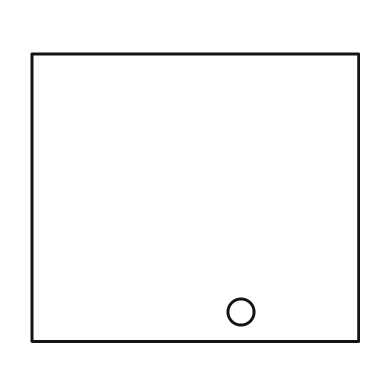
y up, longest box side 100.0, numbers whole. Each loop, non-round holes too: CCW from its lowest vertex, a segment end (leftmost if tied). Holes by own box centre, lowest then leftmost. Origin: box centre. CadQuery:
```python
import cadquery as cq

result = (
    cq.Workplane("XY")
    .moveTo(-50.0, -44.0)
    .lineTo(50.0, -44.0)
    .lineTo(50.0, 44.0)
    .lineTo(-50.0, 44.0)
    .close()
    .moveTo(14.0, -35.0)
    .circle(4.0)
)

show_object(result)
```